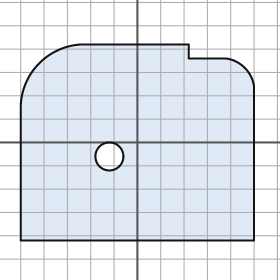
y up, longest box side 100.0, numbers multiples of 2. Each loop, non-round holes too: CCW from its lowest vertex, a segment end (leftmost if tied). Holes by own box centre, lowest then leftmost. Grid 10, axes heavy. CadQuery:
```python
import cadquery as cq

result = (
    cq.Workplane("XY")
    .moveTo(-50.0, -42.0)
    .lineTo(50.0, -42.0)
    .lineTo(50.0, 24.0)
    .threePointArc((46.0, 32.0), (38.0, 36.0))
    .lineTo(22.0, 36.0)
    .lineTo(22.0, 42.0)
    .lineTo(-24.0, 42.0)
    .threePointArc((-42.0, 34.0), (-50.0, 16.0))
    .close()
    .moveTo(-12.0, -6.0)
    .circle(6.0)
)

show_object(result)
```